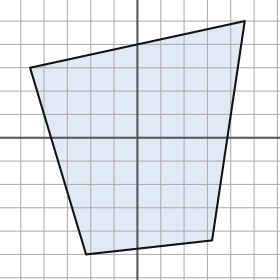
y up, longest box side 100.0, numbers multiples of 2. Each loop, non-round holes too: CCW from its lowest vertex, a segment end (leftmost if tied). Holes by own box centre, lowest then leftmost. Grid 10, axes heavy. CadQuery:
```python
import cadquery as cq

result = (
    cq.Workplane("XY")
    .moveTo(-22.0, -50.0)
    .lineTo(32.0, -44.0)
    .lineTo(46.0, 50.0)
    .lineTo(-46.0, 30.0)
    .close()
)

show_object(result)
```